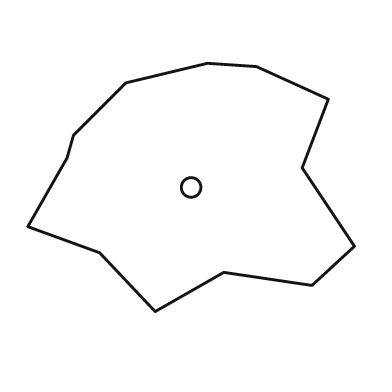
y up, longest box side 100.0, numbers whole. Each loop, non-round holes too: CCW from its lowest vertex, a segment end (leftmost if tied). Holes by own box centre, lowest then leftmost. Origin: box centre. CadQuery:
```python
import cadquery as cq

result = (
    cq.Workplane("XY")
    .moveTo(-11.0, -38.0)
    .lineTo(10.0, -26.0)
    .lineTo(37.0, -30.0)
    .lineTo(50.0, -18.0)
    .lineTo(34.0, 6.0)
    .lineTo(42.0, 27.0)
    .lineTo(20.0, 37.0)
    .lineTo(5.0, 38.0)
    .lineTo(-20.0, 32.0)
    .lineTo(-36.0, 16.0)
    .lineTo(-38.0, 9.0)
    .lineTo(-50.0, -12.0)
    .lineTo(-28.0, -20.0)
    .close()
    .moveTo(0.0, 0.0)
    .circle(3.0)
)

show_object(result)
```